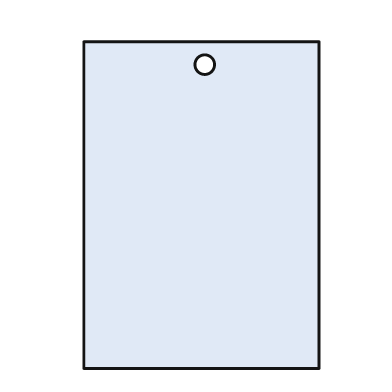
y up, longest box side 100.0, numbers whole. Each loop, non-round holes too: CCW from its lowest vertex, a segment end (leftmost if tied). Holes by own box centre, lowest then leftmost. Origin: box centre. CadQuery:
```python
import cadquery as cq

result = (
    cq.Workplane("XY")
    .moveTo(-36.0, -50.0)
    .lineTo(36.0, -50.0)
    .lineTo(36.0, 50.0)
    .lineTo(-36.0, 50.0)
    .close()
    .moveTo(1.0, 43.0)
    .circle(3.0)
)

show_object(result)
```